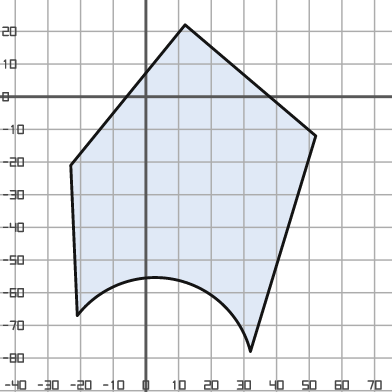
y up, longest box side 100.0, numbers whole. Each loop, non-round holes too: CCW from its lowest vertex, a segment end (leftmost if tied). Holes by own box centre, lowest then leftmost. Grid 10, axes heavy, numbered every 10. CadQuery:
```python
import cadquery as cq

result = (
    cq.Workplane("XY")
    .moveTo(32.0, -78.0)
    .lineTo(52.0, -12.0)
    .lineTo(12.0, 22.0)
    .lineTo(-23.0, -21.0)
    .lineTo(-21.0, -67.0)
    .threePointArc((9.0, -56.0), (32.0, -78.0))
    .close()
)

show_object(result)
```